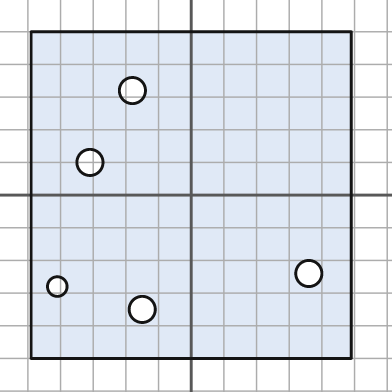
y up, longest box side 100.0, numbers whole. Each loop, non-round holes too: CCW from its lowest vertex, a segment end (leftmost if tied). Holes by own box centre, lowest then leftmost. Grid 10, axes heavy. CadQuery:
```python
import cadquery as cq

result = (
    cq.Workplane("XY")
    .moveTo(-49.0, -50.0)
    .lineTo(49.0, -50.0)
    .lineTo(49.0, 50.0)
    .lineTo(-49.0, 50.0)
    .close()
    .moveTo(-15.0, -35.0)
    .circle(4.0)
    .moveTo(-41.0, -28.0)
    .circle(3.0)
    .moveTo(36.0, -24.0)
    .circle(4.0)
    .moveTo(-31.0, 10.0)
    .circle(4.0)
    .moveTo(-18.0, 32.0)
    .circle(4.0)
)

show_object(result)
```